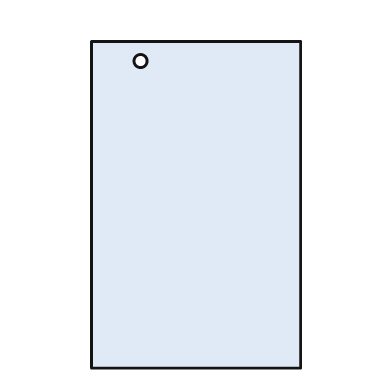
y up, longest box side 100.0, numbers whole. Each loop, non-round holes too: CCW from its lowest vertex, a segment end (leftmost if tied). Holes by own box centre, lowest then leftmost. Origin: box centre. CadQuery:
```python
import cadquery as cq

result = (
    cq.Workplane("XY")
    .moveTo(-32.0, -50.0)
    .lineTo(32.0, -50.0)
    .lineTo(32.0, 50.0)
    .lineTo(-32.0, 50.0)
    .close()
    .moveTo(-17.0, 44.0)
    .circle(2.0)
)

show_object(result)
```